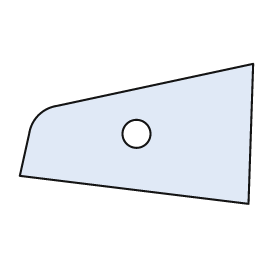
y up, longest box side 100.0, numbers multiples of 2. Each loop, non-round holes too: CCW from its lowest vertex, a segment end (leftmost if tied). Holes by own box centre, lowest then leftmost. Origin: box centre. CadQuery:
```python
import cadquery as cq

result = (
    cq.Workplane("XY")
    .moveTo(48.0, -30.0)
    .lineTo(50.0, 30.0)
    .lineTo(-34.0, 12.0)
    .threePointArc((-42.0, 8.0), (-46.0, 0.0))
    .lineTo(-50.0, -18.0)
    .close()
    .moveTo(0.0, 0.0)
    .circle(6.0)
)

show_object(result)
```